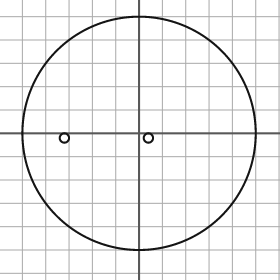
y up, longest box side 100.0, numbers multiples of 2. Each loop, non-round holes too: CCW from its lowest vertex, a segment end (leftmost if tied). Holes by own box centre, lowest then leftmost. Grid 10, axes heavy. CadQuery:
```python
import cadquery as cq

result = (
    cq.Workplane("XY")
    .moveTo(0.0, 0.0)
    .circle(50.0)
    .moveTo(-32.0, -2.0)
    .circle(2.0)
    .moveTo(4.0, -2.0)
    .circle(2.0)
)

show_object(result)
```